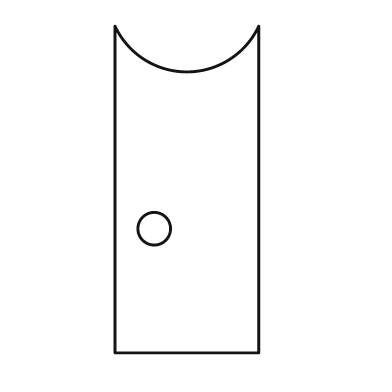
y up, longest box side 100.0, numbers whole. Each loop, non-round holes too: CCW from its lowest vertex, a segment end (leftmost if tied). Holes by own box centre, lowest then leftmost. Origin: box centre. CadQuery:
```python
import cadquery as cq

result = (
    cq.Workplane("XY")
    .moveTo(-22.0, -50.0)
    .lineTo(22.0, -50.0)
    .lineTo(22.0, 50.0)
    .threePointArc((0.0, 36.0), (-22.0, 50.0))
    .close()
    .moveTo(-10.0, -12.0)
    .circle(5.0)
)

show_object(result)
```